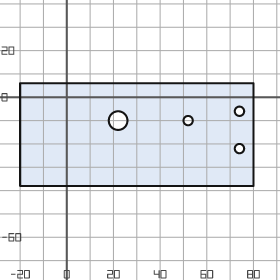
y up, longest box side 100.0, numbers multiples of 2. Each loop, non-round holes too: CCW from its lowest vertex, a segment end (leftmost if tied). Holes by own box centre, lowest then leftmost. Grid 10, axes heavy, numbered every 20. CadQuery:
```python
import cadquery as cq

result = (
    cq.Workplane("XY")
    .moveTo(-20.0, -38.0)
    .lineTo(80.0, -38.0)
    .lineTo(80.0, 6.0)
    .lineTo(-20.0, 6.0)
    .close()
    .moveTo(74.0, -22.0)
    .circle(2.0)
    .moveTo(22.0, -10.0)
    .circle(4.0)
    .moveTo(52.0, -10.0)
    .circle(2.0)
    .moveTo(74.0, -6.0)
    .circle(2.0)
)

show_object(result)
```